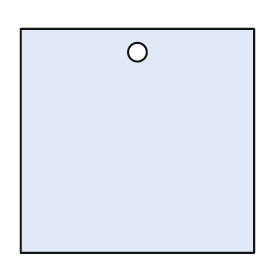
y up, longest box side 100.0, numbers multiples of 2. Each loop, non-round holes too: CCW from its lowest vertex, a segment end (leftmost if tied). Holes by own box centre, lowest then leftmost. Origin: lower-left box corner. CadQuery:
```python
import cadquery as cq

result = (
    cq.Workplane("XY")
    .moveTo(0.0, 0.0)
    .lineTo(100.0, 0.0)
    .lineTo(100.0, 96.0)
    .lineTo(0.0, 96.0)
    .close()
    .moveTo(50.0, 86.0)
    .circle(4.0)
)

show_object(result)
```